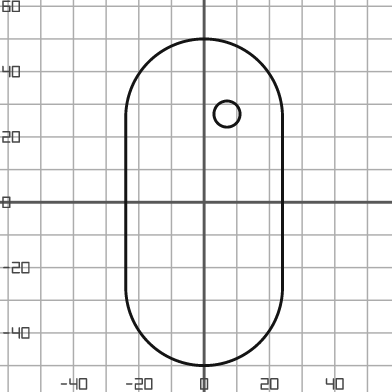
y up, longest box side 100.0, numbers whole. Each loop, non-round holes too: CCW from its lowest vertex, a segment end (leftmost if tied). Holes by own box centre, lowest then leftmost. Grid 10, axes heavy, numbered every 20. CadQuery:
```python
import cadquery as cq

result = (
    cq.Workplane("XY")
    .moveTo(-24.0, -26.0)
    .threePointArc((0.0, -50.0), (24.0, -26.0))
    .lineTo(24.0, 26.0)
    .threePointArc((0.0, 50.0), (-24.0, 26.0))
    .close()
    .moveTo(7.0, 27.0)
    .circle(4.0)
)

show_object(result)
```